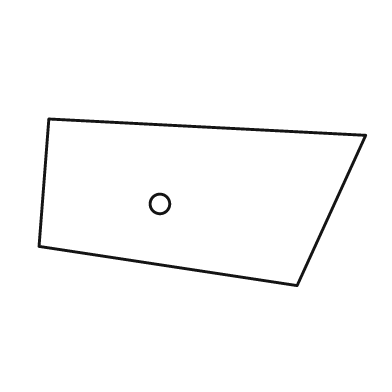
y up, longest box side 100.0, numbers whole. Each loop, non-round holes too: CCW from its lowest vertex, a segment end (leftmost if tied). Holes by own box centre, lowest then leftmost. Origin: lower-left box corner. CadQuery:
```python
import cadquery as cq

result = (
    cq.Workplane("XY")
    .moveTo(79.0, 0.0)
    .lineTo(100.0, 46.0)
    .lineTo(3.0, 51.0)
    .lineTo(0.0, 12.0)
    .close()
    .moveTo(37.0, 25.0)
    .circle(3.0)
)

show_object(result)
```